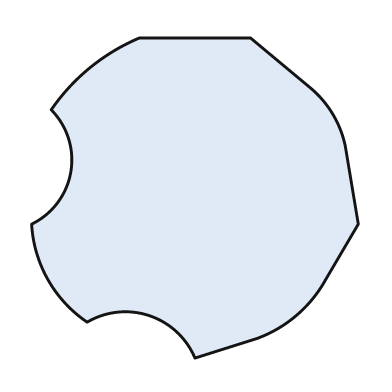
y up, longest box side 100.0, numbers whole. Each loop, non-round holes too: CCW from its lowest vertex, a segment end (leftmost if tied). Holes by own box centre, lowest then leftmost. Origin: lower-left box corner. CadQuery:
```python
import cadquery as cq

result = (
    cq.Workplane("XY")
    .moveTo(50.0, 0.0)
    .lineTo(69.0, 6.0)
    .threePointArc((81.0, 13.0), (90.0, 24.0))
    .lineTo(100.0, 41.0)
    .lineTo(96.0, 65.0)
    .threePointArc((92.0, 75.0), (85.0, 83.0))
    .lineTo(67.0, 98.0)
    .lineTo(33.0, 98.0)
    .threePointArc((18.0, 89.0), (6.0, 76.0))
    .threePointArc((12.0, 57.0), (0.0, 41.0))
    .threePointArc((5.0, 24.0), (17.0, 11.0))
    .threePointArc((36.0, 13.0), (50.0, 0.0))
    .close()
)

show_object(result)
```